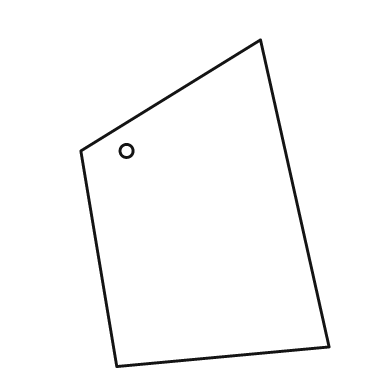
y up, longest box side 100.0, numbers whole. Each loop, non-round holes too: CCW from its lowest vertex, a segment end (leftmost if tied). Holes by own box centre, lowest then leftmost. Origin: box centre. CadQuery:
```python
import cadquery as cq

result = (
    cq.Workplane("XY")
    .moveTo(-27.0, -50.0)
    .lineTo(38.0, -44.0)
    .lineTo(17.0, 50.0)
    .lineTo(-38.0, 16.0)
    .close()
    .moveTo(-24.0, 16.0)
    .circle(2.0)
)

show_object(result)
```